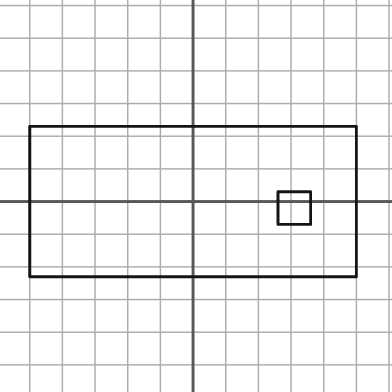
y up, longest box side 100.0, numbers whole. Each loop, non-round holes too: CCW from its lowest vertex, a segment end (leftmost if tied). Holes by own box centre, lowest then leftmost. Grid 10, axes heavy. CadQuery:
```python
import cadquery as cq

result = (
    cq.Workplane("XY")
    .moveTo(-50.0, -23.0)
    .lineTo(50.0, -23.0)
    .lineTo(50.0, 23.0)
    .lineTo(-50.0, 23.0)
    .close()
    .moveTo(26.0, -7.0)
    .lineTo(36.0, -7.0)
    .lineTo(36.0, 3.0)
    .lineTo(26.0, 3.0)
    .close()
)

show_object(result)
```